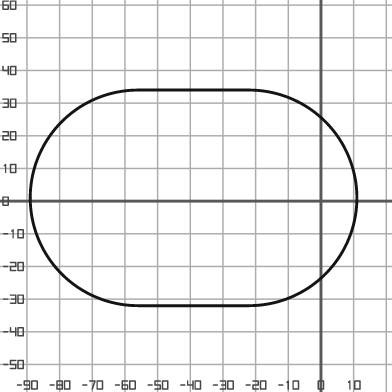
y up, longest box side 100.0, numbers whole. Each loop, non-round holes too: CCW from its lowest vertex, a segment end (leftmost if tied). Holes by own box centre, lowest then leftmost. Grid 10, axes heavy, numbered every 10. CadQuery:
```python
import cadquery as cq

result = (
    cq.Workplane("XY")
    .moveTo(-56.0, -32.0)
    .lineTo(-22.0, -32.0)
    .threePointArc((11.0, 1.0), (-22.0, 34.0))
    .lineTo(-56.0, 34.0)
    .threePointArc((-89.0, 1.0), (-56.0, -32.0))
    .close()
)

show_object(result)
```